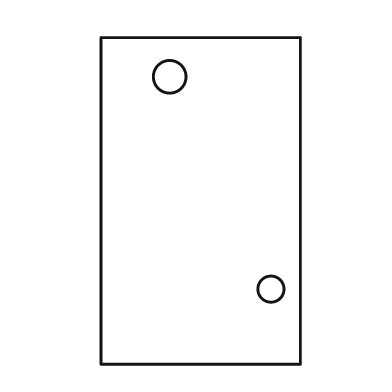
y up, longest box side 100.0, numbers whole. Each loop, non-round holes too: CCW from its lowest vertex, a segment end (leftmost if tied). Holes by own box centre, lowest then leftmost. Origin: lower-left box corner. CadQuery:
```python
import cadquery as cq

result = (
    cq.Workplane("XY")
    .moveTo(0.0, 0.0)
    .lineTo(61.0, 0.0)
    .lineTo(61.0, 100.0)
    .lineTo(0.0, 100.0)
    .close()
    .moveTo(52.0, 23.0)
    .circle(4.0)
    .moveTo(21.0, 88.0)
    .circle(5.0)
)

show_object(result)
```